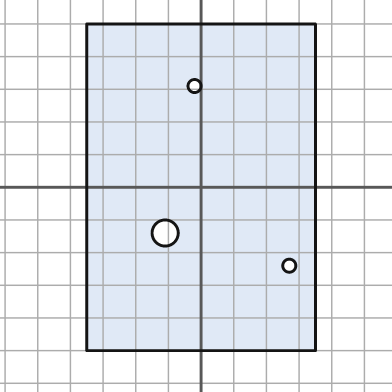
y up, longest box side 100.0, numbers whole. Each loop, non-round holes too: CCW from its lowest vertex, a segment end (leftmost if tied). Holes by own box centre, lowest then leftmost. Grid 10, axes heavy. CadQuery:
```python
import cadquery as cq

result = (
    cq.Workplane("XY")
    .moveTo(-35.0, -50.0)
    .lineTo(35.0, -50.0)
    .lineTo(35.0, 50.0)
    .lineTo(-35.0, 50.0)
    .close()
    .moveTo(27.0, -24.0)
    .circle(2.0)
    .moveTo(-11.0, -14.0)
    .circle(4.0)
    .moveTo(-2.0, 31.0)
    .circle(2.0)
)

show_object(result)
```